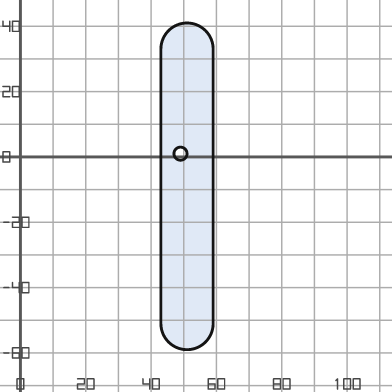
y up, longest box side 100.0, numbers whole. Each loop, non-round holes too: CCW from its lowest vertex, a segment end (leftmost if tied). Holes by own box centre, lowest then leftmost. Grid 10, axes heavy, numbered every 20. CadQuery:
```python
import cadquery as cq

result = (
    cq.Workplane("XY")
    .moveTo(43.0, -51.0)
    .threePointArc((51.0, -59.0), (59.0, -51.0))
    .lineTo(59.0, 33.0)
    .threePointArc((51.0, 41.0), (43.0, 33.0))
    .close()
    .moveTo(49.0, 1.0)
    .circle(2.0)
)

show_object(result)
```